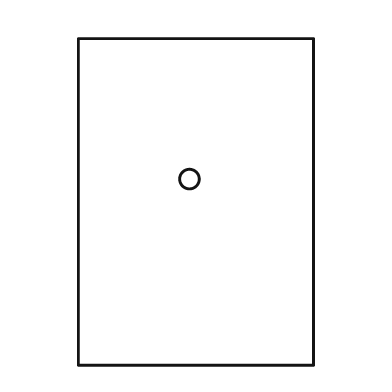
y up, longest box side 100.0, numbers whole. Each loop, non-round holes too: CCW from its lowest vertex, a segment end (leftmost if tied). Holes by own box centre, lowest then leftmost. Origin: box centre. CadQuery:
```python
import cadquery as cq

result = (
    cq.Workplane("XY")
    .moveTo(-36.0, -50.0)
    .lineTo(36.0, -50.0)
    .lineTo(36.0, 50.0)
    .lineTo(-36.0, 50.0)
    .close()
    .moveTo(-2.0, 7.0)
    .circle(3.0)
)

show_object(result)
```